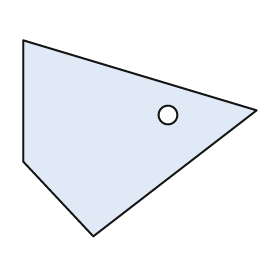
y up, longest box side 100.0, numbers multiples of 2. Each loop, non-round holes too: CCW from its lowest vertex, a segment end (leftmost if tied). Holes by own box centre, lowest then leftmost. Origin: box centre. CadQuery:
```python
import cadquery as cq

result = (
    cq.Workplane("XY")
    .moveTo(-20.0, -42.0)
    .lineTo(50.0, 12.0)
    .lineTo(-50.0, 42.0)
    .lineTo(-50.0, -10.0)
    .close()
    .moveTo(12.0, 10.0)
    .circle(4.0)
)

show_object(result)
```